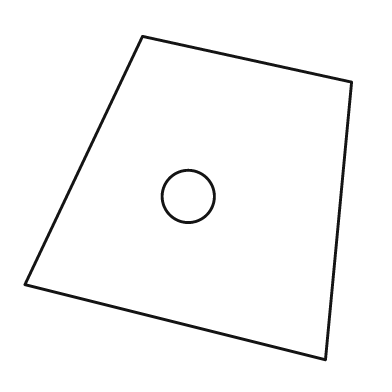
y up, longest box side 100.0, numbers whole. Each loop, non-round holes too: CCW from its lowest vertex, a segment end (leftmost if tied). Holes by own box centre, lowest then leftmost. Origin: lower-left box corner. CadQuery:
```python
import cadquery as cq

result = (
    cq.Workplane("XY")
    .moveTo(92.0, 0.0)
    .lineTo(100.0, 85.0)
    .lineTo(36.0, 99.0)
    .lineTo(0.0, 23.0)
    .close()
    .moveTo(50.0, 50.0)
    .circle(8.0)
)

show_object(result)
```